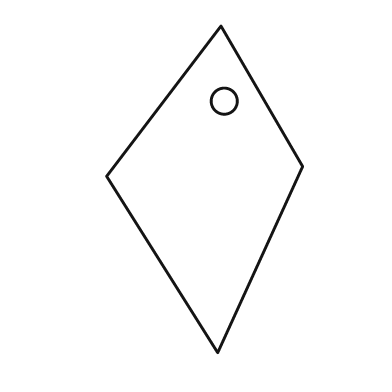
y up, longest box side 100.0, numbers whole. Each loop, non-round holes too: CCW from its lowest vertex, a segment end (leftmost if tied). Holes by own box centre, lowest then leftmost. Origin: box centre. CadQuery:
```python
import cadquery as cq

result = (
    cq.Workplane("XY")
    .moveTo(4.0, -50.0)
    .lineTo(30.0, 7.0)
    .lineTo(5.0, 50.0)
    .lineTo(-30.0, 4.0)
    .close()
    .moveTo(6.0, 27.0)
    .circle(4.0)
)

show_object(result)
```